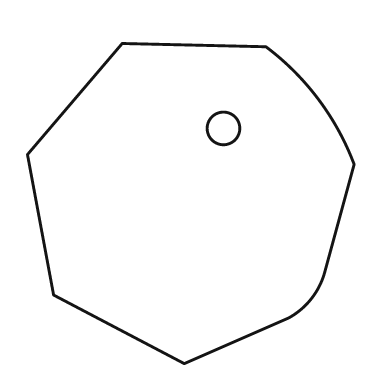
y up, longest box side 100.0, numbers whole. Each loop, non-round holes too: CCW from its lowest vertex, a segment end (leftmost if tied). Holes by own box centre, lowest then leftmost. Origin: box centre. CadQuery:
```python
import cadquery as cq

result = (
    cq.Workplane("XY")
    .moveTo(-2.0, -49.0)
    .lineTo(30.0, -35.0)
    .threePointArc((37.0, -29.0), (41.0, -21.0))
    .lineTo(50.0, 12.0)
    .threePointArc((39.0, 32.0), (23.0, 48.0))
    .lineTo(-21.0, 49.0)
    .lineTo(-50.0, 15.0)
    .lineTo(-42.0, -28.0)
    .close()
    .moveTo(10.0, 23.0)
    .circle(5.0)
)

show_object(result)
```